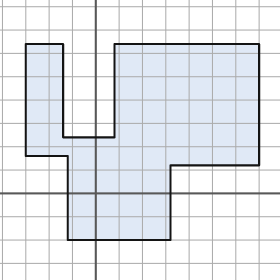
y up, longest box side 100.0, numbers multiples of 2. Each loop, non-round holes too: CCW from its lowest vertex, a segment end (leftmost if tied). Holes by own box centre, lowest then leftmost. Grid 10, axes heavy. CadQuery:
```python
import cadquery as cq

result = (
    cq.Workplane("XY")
    .moveTo(-12.0, -20.0)
    .lineTo(32.0, -20.0)
    .lineTo(32.0, 12.0)
    .lineTo(70.0, 12.0)
    .lineTo(70.0, 64.0)
    .lineTo(8.0, 64.0)
    .lineTo(8.0, 24.0)
    .lineTo(-14.0, 24.0)
    .lineTo(-14.0, 64.0)
    .lineTo(-30.0, 64.0)
    .lineTo(-30.0, 16.0)
    .lineTo(-12.0, 16.0)
    .close()
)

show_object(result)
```